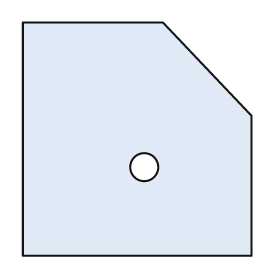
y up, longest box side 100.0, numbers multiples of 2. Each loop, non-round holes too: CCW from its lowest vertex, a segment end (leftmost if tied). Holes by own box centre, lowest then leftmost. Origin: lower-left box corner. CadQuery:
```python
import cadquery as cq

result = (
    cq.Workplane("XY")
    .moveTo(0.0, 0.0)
    .lineTo(98.0, 0.0)
    .lineTo(98.0, 60.0)
    .lineTo(60.0, 100.0)
    .lineTo(0.0, 100.0)
    .close()
    .moveTo(52.0, 38.0)
    .circle(6.0)
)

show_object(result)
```